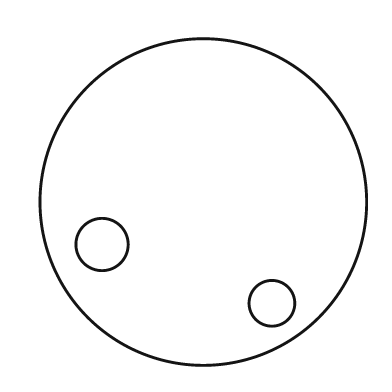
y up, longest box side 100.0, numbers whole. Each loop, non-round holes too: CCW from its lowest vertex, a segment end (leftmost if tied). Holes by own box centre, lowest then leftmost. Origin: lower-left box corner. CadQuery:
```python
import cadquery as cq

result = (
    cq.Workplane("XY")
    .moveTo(50.0, 50.0)
    .circle(50.0)
    .moveTo(71.0, 19.0)
    .circle(7.0)
    .moveTo(19.0, 37.0)
    .circle(8.0)
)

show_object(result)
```